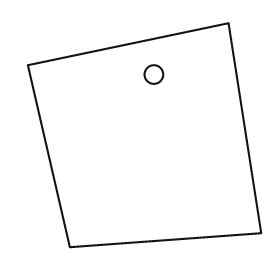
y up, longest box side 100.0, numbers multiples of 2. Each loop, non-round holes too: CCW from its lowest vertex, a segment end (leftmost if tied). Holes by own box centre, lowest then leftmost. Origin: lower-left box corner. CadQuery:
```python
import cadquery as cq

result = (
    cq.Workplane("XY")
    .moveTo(18.0, 0.0)
    .lineTo(100.0, 6.0)
    .lineTo(86.0, 96.0)
    .lineTo(0.0, 78.0)
    .close()
    .moveTo(54.0, 74.0)
    .circle(4.0)
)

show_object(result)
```